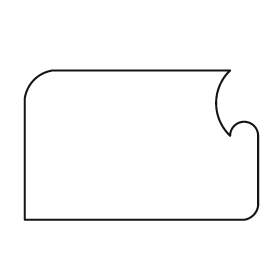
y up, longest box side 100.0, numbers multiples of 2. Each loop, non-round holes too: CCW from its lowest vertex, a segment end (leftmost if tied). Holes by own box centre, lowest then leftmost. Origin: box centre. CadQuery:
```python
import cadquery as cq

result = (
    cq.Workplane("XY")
    .moveTo(-50.0, -32.0)
    .lineTo(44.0, -32.0)
    .threePointArc((48.0, -30.0), (50.0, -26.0))
    .lineTo(50.0, 4.0)
    .threePointArc((44.0, 10.0), (38.0, 4.0))
    .threePointArc((32.0, 18.0), (38.0, 32.0))
    .lineTo(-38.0, 32.0)
    .threePointArc((-46.0, 28.0), (-50.0, 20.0))
    .close()
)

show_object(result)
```